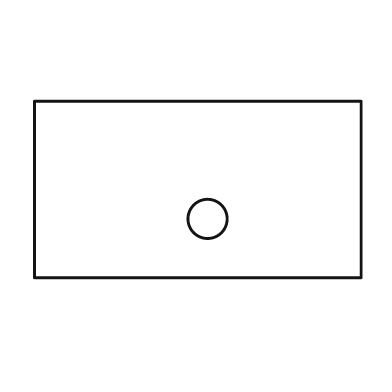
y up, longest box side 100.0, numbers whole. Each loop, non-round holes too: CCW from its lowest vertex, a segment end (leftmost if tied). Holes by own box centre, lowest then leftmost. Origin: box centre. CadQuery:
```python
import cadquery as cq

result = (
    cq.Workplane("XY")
    .moveTo(-50.0, -27.0)
    .lineTo(50.0, -27.0)
    .lineTo(50.0, 27.0)
    .lineTo(-50.0, 27.0)
    .close()
    .moveTo(3.0, -9.0)
    .circle(6.0)
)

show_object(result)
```